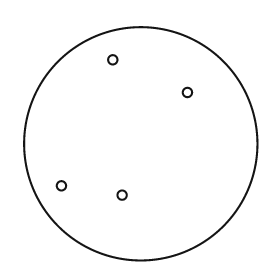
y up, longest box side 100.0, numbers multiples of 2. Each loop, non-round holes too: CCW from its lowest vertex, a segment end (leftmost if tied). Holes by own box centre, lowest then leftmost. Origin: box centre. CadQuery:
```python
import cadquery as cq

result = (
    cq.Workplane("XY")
    .moveTo(0.0, 0.0)
    .circle(50.0)
    .moveTo(-8.0, -22.0)
    .circle(2.0)
    .moveTo(-34.0, -18.0)
    .circle(2.0)
    .moveTo(20.0, 22.0)
    .circle(2.0)
    .moveTo(-12.0, 36.0)
    .circle(2.0)
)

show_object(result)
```